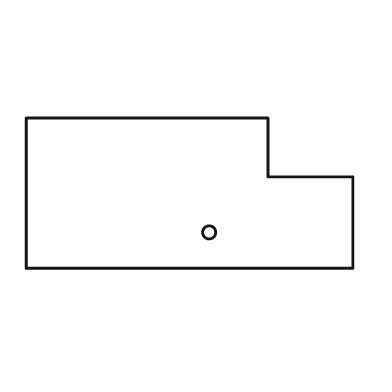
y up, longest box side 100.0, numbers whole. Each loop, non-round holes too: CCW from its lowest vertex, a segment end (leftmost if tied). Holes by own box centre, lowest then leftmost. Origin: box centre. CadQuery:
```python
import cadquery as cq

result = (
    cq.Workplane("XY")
    .moveTo(-50.0, -23.0)
    .lineTo(50.0, -23.0)
    .lineTo(50.0, 5.0)
    .lineTo(24.0, 5.0)
    .lineTo(24.0, 23.0)
    .lineTo(-50.0, 23.0)
    .close()
    .moveTo(6.0, -12.0)
    .circle(2.0)
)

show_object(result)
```